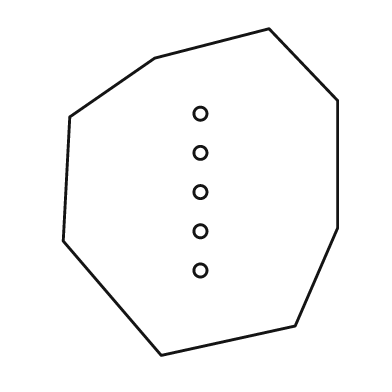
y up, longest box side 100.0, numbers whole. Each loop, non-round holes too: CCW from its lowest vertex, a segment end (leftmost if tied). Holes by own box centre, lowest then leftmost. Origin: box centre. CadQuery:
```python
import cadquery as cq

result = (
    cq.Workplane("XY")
    .moveTo(-12.0, -50.0)
    .lineTo(29.0, -41.0)
    .lineTo(42.0, -11.0)
    .lineTo(42.0, 28.0)
    .lineTo(21.0, 50.0)
    .lineTo(-14.0, 41.0)
    .lineTo(-40.0, 23.0)
    .lineTo(-42.0, -15.0)
    .close()
    .moveTo(0.0, -24.0)
    .circle(2.0)
    .moveTo(0.0, -12.0)
    .circle(2.0)
    .moveTo(0.0, 0.0)
    .circle(2.0)
    .moveTo(0.0, 12.0)
    .circle(2.0)
    .moveTo(0.0, 24.0)
    .circle(2.0)
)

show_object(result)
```